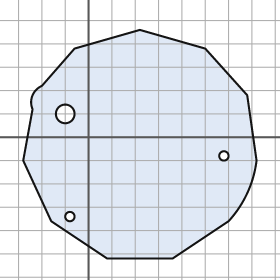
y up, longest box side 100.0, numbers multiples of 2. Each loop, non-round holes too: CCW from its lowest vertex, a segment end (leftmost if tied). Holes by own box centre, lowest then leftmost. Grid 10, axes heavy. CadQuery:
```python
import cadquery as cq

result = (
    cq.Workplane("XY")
    .moveTo(8.0, -52.0)
    .lineTo(36.0, -52.0)
    .lineTo(60.0, -36.0)
    .threePointArc((68.0, -24.0), (72.0, -10.0))
    .lineTo(68.0, 18.0)
    .lineTo(50.0, 38.0)
    .lineTo(22.0, 46.0)
    .lineTo(-6.0, 38.0)
    .lineTo(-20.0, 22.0)
    .threePointArc((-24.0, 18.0), (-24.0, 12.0))
    .lineTo(-28.0, -10.0)
    .lineTo(-16.0, -36.0)
    .close()
    .moveTo(-8.0, -34.0)
    .circle(2.0)
    .moveTo(58.0, -8.0)
    .circle(2.0)
    .moveTo(-10.0, 10.0)
    .circle(4.0)
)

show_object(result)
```